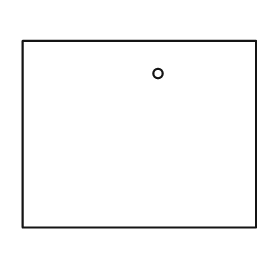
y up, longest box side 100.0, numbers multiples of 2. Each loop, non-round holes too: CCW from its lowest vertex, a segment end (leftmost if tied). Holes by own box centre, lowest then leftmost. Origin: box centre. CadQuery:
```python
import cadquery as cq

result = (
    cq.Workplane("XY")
    .moveTo(-50.0, -40.0)
    .lineTo(50.0, -40.0)
    .lineTo(50.0, 40.0)
    .lineTo(-50.0, 40.0)
    .close()
    .moveTo(8.0, 26.0)
    .circle(2.0)
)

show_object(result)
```